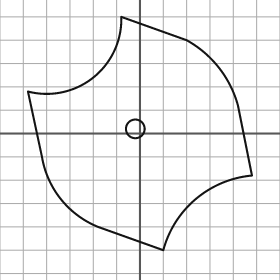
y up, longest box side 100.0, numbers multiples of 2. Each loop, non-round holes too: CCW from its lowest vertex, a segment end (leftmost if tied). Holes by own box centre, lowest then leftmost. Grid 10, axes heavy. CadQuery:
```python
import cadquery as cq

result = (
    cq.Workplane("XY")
    .moveTo(10.0, -50.0)
    .threePointArc((24.0, -28.0), (48.0, -18.0))
    .lineTo(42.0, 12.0)
    .threePointArc((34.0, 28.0), (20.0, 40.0))
    .lineTo(-8.0, 50.0)
    .threePointArc((-20.0, 24.0), (-48.0, 18.0))
    .lineTo(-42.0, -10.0)
    .threePointArc((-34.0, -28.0), (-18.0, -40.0))
    .close()
    .moveTo(-2.0, 2.0)
    .circle(4.0)
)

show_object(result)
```